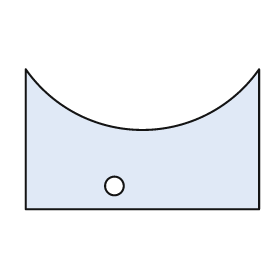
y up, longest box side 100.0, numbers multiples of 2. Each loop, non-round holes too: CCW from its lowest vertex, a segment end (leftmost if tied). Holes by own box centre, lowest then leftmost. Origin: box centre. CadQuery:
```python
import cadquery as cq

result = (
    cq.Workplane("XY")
    .moveTo(-50.0, -30.0)
    .lineTo(50.0, -30.0)
    .lineTo(50.0, 30.0)
    .threePointArc((0.0, 4.0), (-50.0, 30.0))
    .close()
    .moveTo(-12.0, -20.0)
    .circle(4.0)
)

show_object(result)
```